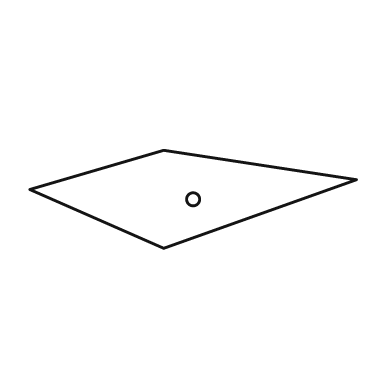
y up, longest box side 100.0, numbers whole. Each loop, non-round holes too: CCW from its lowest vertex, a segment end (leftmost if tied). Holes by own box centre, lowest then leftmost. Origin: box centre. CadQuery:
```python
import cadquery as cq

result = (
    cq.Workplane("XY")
    .moveTo(-9.0, -15.0)
    .lineTo(50.0, 6.0)
    .lineTo(-9.0, 15.0)
    .lineTo(-50.0, 3.0)
    .close()
    .moveTo(0.0, 0.0)
    .circle(2.0)
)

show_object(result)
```